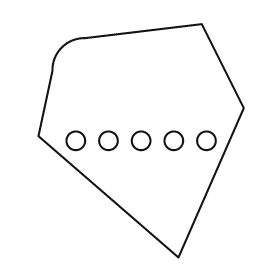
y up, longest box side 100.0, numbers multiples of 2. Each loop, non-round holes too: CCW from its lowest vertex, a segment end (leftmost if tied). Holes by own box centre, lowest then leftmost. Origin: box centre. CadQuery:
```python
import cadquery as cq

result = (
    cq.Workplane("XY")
    .moveTo(16.0, -50.0)
    .lineTo(44.0, 14.0)
    .lineTo(26.0, 50.0)
    .lineTo(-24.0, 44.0)
    .threePointArc((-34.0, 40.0), (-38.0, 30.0))
    .lineTo(-44.0, 2.0)
    .close()
    .moveTo(-28.0, 0.0)
    .circle(4.0)
    .moveTo(-14.0, 0.0)
    .circle(4.0)
    .moveTo(0.0, 0.0)
    .circle(4.0)
    .moveTo(14.0, 0.0)
    .circle(4.0)
    .moveTo(28.0, 0.0)
    .circle(4.0)
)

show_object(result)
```